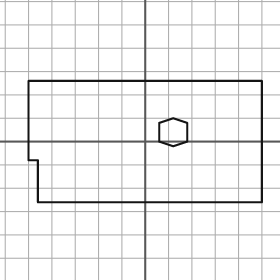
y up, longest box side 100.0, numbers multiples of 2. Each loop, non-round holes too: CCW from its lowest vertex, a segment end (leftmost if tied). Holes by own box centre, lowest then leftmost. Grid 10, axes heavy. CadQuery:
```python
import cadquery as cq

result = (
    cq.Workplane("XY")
    .moveTo(-46.0, -26.0)
    .lineTo(50.0, -26.0)
    .lineTo(50.0, 26.0)
    .lineTo(-50.0, 26.0)
    .lineTo(-50.0, -8.0)
    .lineTo(-46.0, -8.0)
    .close()
    .moveTo(12.0, -2.0)
    .lineTo(18.0, 0.0)
    .lineTo(18.0, 8.0)
    .lineTo(12.0, 10.0)
    .lineTo(6.0, 8.0)
    .lineTo(6.0, 0.0)
    .close()
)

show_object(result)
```